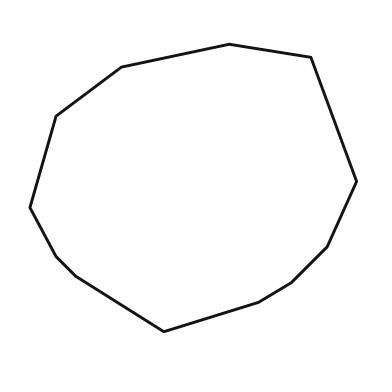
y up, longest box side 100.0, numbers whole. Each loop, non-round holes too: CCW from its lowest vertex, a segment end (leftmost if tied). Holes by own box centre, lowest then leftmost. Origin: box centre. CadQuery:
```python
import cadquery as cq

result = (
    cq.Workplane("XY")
    .moveTo(-9.0, -44.0)
    .lineTo(20.0, -35.0)
    .lineTo(30.0, -29.0)
    .lineTo(41.0, -18.0)
    .lineTo(50.0, 2.0)
    .lineTo(36.0, 40.0)
    .lineTo(11.0, 44.0)
    .lineTo(-22.0, 37.0)
    .lineTo(-42.0, 22.0)
    .lineTo(-50.0, -6.0)
    .lineTo(-42.0, -21.0)
    .lineTo(-36.0, -27.0)
    .close()
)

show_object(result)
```